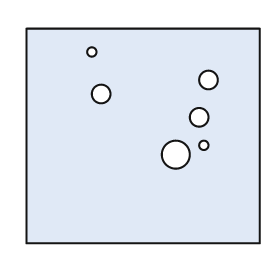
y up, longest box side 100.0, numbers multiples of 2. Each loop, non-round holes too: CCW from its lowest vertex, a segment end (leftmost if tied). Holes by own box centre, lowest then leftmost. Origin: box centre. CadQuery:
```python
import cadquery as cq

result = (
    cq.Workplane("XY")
    .moveTo(-50.0, -46.0)
    .lineTo(50.0, -46.0)
    .lineTo(50.0, 46.0)
    .lineTo(-50.0, 46.0)
    .close()
    .moveTo(14.0, -8.0)
    .circle(6.0)
    .moveTo(26.0, -4.0)
    .circle(2.0)
    .moveTo(24.0, 8.0)
    .circle(4.0)
    .moveTo(-18.0, 18.0)
    .circle(4.0)
    .moveTo(28.0, 24.0)
    .circle(4.0)
    .moveTo(-22.0, 36.0)
    .circle(2.0)
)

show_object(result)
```